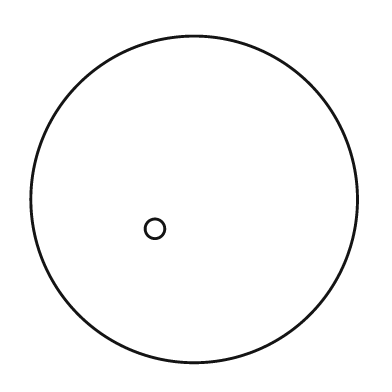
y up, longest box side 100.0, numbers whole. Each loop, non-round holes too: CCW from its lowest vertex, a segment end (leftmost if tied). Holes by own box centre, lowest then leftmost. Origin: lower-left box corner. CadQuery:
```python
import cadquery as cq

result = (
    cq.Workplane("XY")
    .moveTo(50.0, 50.0)
    .circle(50.0)
    .moveTo(38.0, 41.0)
    .circle(3.0)
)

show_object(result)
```